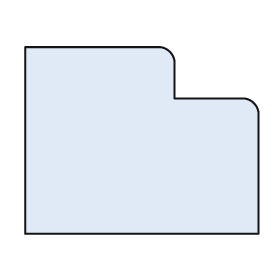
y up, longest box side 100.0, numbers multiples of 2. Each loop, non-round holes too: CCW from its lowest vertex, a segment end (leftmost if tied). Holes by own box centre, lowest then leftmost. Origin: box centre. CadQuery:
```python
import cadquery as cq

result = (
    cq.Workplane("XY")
    .moveTo(-50.0, -40.0)
    .lineTo(50.0, -40.0)
    .lineTo(50.0, 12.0)
    .threePointArc((48.0, 16.0), (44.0, 18.0))
    .lineTo(14.0, 18.0)
    .lineTo(14.0, 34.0)
    .threePointArc((12.0, 38.0), (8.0, 40.0))
    .lineTo(-50.0, 40.0)
    .close()
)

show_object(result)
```